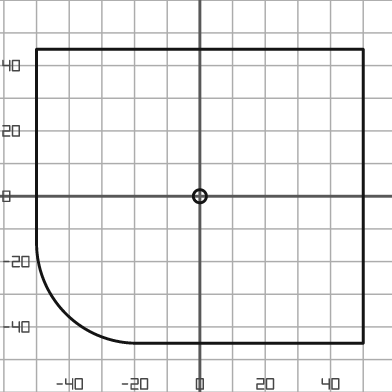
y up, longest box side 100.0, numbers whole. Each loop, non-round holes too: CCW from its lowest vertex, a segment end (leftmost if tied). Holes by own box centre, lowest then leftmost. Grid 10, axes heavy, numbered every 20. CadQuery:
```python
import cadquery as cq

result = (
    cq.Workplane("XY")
    .moveTo(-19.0, -45.0)
    .lineTo(50.0, -45.0)
    .lineTo(50.0, 45.0)
    .lineTo(-50.0, 45.0)
    .lineTo(-50.0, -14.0)
    .threePointArc((-41.0, -36.0), (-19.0, -45.0))
    .close()
    .moveTo(0.0, 0.0)
    .circle(2.0)
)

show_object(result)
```